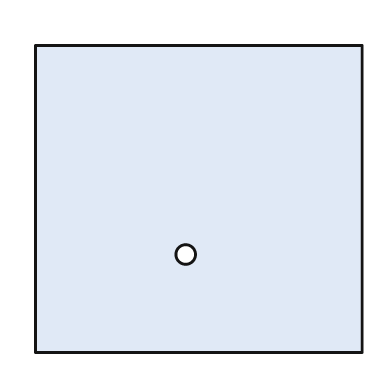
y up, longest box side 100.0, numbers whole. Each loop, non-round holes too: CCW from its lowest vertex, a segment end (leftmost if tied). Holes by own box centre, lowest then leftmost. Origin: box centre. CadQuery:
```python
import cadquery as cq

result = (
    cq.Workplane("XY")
    .moveTo(-50.0, -47.0)
    .lineTo(50.0, -47.0)
    .lineTo(50.0, 47.0)
    .lineTo(-50.0, 47.0)
    .close()
    .moveTo(-4.0, -17.0)
    .circle(3.0)
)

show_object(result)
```